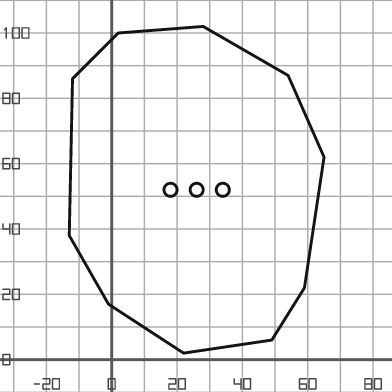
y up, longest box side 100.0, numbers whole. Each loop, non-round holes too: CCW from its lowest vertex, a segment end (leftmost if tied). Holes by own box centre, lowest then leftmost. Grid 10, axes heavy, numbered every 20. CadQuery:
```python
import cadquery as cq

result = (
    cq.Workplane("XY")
    .moveTo(22.0, 2.0)
    .lineTo(49.0, 6.0)
    .lineTo(59.0, 22.0)
    .lineTo(65.0, 62.0)
    .lineTo(54.0, 87.0)
    .lineTo(28.0, 102.0)
    .lineTo(2.0, 100.0)
    .lineTo(-12.0, 86.0)
    .lineTo(-13.0, 38.0)
    .lineTo(-1.0, 17.0)
    .close()
    .moveTo(18.0, 52.0)
    .circle(2.0)
    .moveTo(26.0, 52.0)
    .circle(2.0)
    .moveTo(34.0, 52.0)
    .circle(2.0)
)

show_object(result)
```